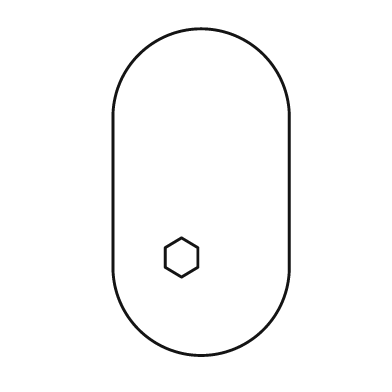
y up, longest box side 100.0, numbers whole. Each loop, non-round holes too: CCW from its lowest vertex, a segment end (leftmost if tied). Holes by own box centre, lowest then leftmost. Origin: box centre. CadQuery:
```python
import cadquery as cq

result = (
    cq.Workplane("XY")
    .moveTo(-27.0, -23.0)
    .threePointArc((0.0, -50.0), (27.0, -23.0))
    .lineTo(27.0, 23.0)
    .threePointArc((0.0, 50.0), (-27.0, 23.0))
    .close()
    .moveTo(-6.0, -26.0)
    .lineTo(-1.0, -23.0)
    .lineTo(-1.0, -17.0)
    .lineTo(-6.0, -14.0)
    .lineTo(-11.0, -17.0)
    .lineTo(-11.0, -23.0)
    .close()
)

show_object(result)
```